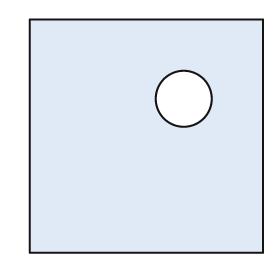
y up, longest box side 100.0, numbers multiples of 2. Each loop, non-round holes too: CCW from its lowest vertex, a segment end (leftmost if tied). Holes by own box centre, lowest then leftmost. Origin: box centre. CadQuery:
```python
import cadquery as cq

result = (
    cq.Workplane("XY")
    .moveTo(-50.0, -50.0)
    .lineTo(50.0, -50.0)
    .lineTo(50.0, 50.0)
    .lineTo(-50.0, 50.0)
    .close()
    .moveTo(16.0, 16.0)
    .circle(12.0)
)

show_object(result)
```